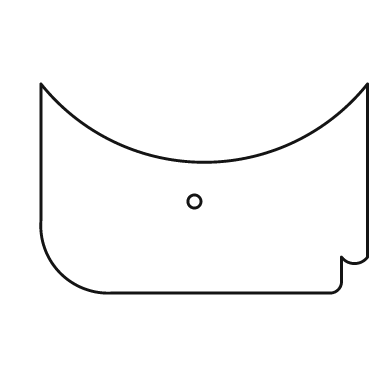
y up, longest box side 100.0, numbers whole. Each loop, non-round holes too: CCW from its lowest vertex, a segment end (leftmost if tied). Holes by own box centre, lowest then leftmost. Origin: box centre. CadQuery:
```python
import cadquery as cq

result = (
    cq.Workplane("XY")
    .moveTo(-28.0, -32.0)
    .lineTo(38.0, -32.0)
    .threePointArc((41.0, -31.0), (42.0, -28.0))
    .lineTo(42.0, -21.0)
    .threePointArc((46.0, -23.0), (50.0, -21.0))
    .lineTo(50.0, 32.0)
    .threePointArc((0.0, 8.0), (-50.0, 32.0))
    .lineTo(-50.0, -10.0)
    .threePointArc((-44.0, -26.0), (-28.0, -32.0))
    .close()
    .moveTo(-3.0, -4.0)
    .circle(2.0)
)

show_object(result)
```